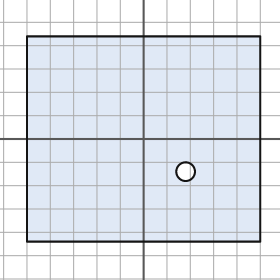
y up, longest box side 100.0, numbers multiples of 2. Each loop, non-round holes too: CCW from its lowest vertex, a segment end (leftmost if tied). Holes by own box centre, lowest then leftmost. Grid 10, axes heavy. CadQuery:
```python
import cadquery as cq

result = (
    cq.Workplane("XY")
    .moveTo(-50.0, -44.0)
    .lineTo(50.0, -44.0)
    .lineTo(50.0, 44.0)
    .lineTo(-50.0, 44.0)
    .close()
    .moveTo(18.0, -14.0)
    .circle(4.0)
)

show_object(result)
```